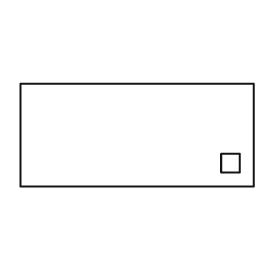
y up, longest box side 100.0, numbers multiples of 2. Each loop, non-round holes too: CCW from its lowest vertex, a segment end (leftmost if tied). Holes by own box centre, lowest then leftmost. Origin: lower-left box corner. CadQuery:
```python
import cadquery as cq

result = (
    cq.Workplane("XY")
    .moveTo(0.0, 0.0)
    .lineTo(100.0, 0.0)
    .lineTo(100.0, 44.0)
    .lineTo(0.0, 44.0)
    .close()
    .moveTo(86.0, 6.0)
    .lineTo(94.0, 6.0)
    .lineTo(94.0, 14.0)
    .lineTo(86.0, 14.0)
    .close()
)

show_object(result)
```